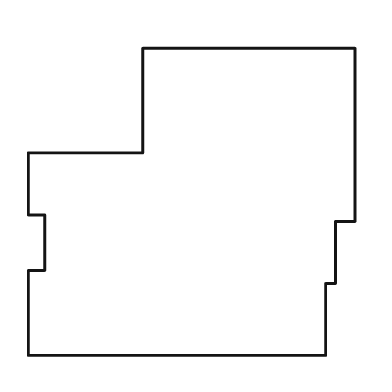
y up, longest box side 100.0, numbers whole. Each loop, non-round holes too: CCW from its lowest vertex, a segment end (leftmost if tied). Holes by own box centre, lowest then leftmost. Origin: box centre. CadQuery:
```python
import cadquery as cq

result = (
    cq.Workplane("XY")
    .moveTo(-50.0, -47.0)
    .lineTo(41.0, -47.0)
    .lineTo(41.0, -25.0)
    .lineTo(44.0, -25.0)
    .lineTo(44.0, -6.0)
    .lineTo(50.0, -6.0)
    .lineTo(50.0, 47.0)
    .lineTo(-15.0, 47.0)
    .lineTo(-15.0, 15.0)
    .lineTo(-50.0, 15.0)
    .lineTo(-50.0, -4.0)
    .lineTo(-45.0, -4.0)
    .lineTo(-45.0, -21.0)
    .lineTo(-50.0, -21.0)
    .close()
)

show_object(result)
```